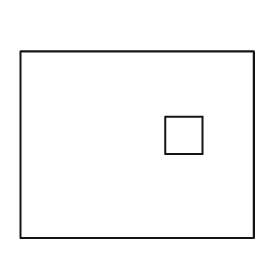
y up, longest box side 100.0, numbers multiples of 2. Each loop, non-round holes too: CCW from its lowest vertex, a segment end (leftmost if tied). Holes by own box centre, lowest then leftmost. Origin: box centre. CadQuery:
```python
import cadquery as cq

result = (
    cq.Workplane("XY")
    .moveTo(-50.0, -40.0)
    .lineTo(50.0, -40.0)
    .lineTo(50.0, 40.0)
    .lineTo(-50.0, 40.0)
    .close()
    .moveTo(12.0, -4.0)
    .lineTo(28.0, -4.0)
    .lineTo(28.0, 12.0)
    .lineTo(12.0, 12.0)
    .close()
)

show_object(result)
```